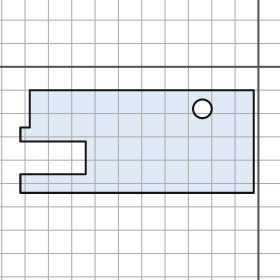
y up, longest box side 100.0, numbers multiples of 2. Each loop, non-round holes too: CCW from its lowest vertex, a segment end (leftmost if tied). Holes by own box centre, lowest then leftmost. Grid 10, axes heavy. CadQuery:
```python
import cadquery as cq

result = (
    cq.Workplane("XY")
    .moveTo(-102.0, -54.0)
    .lineTo(-2.0, -54.0)
    .lineTo(-2.0, -10.0)
    .lineTo(-98.0, -10.0)
    .lineTo(-98.0, -26.0)
    .lineTo(-102.0, -26.0)
    .lineTo(-102.0, -32.0)
    .lineTo(-74.0, -32.0)
    .lineTo(-74.0, -46.0)
    .lineTo(-102.0, -46.0)
    .close()
    .moveTo(-24.0, -18.0)
    .circle(4.0)
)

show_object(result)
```